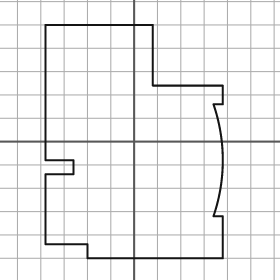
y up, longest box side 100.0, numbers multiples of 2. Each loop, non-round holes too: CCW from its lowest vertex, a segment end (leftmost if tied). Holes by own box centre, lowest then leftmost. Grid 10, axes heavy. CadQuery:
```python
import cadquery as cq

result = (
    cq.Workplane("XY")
    .moveTo(-20.0, -50.0)
    .lineTo(38.0, -50.0)
    .lineTo(38.0, -32.0)
    .lineTo(34.0, -32.0)
    .threePointArc((38.0, -8.0), (34.0, 16.0))
    .lineTo(38.0, 16.0)
    .lineTo(38.0, 24.0)
    .lineTo(8.0, 24.0)
    .lineTo(8.0, 50.0)
    .lineTo(-38.0, 50.0)
    .lineTo(-38.0, -8.0)
    .lineTo(-26.0, -8.0)
    .lineTo(-26.0, -14.0)
    .lineTo(-38.0, -14.0)
    .lineTo(-38.0, -44.0)
    .lineTo(-20.0, -44.0)
    .close()
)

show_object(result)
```